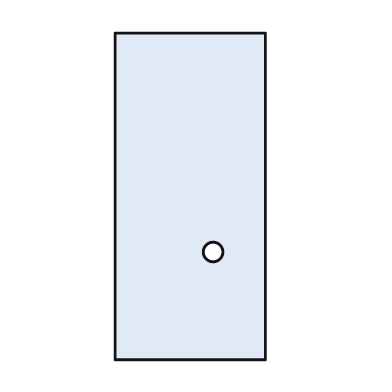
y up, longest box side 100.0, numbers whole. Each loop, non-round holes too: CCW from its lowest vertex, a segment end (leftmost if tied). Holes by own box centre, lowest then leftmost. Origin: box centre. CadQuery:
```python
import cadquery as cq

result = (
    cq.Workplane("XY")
    .moveTo(-23.0, -50.0)
    .lineTo(23.0, -50.0)
    .lineTo(23.0, 50.0)
    .lineTo(-23.0, 50.0)
    .close()
    .moveTo(7.0, -17.0)
    .circle(3.0)
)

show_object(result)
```